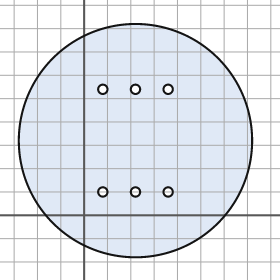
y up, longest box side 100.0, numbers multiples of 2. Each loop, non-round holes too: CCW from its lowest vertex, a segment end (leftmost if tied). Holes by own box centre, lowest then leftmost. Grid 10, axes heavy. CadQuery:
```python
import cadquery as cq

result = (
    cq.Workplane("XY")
    .moveTo(22.0, 32.0)
    .circle(50.0)
    .moveTo(8.0, 10.0)
    .circle(2.0)
    .moveTo(22.0, 10.0)
    .circle(2.0)
    .moveTo(36.0, 10.0)
    .circle(2.0)
    .moveTo(8.0, 54.0)
    .circle(2.0)
    .moveTo(22.0, 54.0)
    .circle(2.0)
    .moveTo(36.0, 54.0)
    .circle(2.0)
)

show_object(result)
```